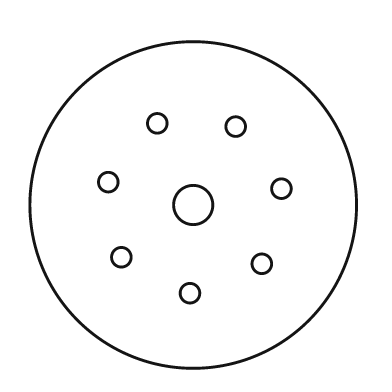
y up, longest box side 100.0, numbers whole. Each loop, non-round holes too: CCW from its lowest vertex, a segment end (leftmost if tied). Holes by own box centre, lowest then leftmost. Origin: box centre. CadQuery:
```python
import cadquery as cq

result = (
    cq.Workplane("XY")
    .moveTo(0.0, 0.0)
    .circle(50.0)
    .moveTo(-1.0, -27.0)
    .circle(3.0)
    .moveTo(21.0, -18.0)
    .circle(3.0)
    .moveTo(-22.0, -16.0)
    .circle(3.0)
    .moveTo(0.0, 0.0)
    .circle(6.0)
    .moveTo(27.0, 5.0)
    .circle(3.0)
    .moveTo(-26.0, 7.0)
    .circle(3.0)
    .moveTo(13.0, 24.0)
    .circle(3.0)
    .moveTo(-11.0, 25.0)
    .circle(3.0)
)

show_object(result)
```